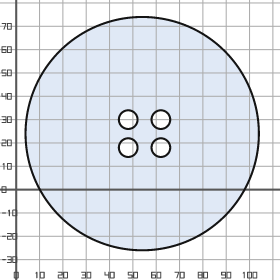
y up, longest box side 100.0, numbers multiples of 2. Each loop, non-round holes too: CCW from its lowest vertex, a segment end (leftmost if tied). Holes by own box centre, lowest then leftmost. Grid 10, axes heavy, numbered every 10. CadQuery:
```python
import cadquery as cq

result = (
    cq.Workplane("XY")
    .moveTo(54.0, 24.0)
    .circle(50.0)
    .moveTo(48.0, 18.0)
    .circle(4.0)
    .moveTo(62.0, 18.0)
    .circle(4.0)
    .moveTo(48.0, 30.0)
    .circle(4.0)
    .moveTo(62.0, 30.0)
    .circle(4.0)
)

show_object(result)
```